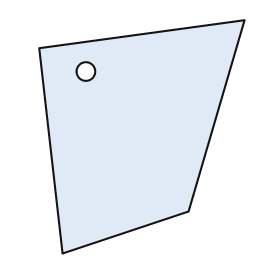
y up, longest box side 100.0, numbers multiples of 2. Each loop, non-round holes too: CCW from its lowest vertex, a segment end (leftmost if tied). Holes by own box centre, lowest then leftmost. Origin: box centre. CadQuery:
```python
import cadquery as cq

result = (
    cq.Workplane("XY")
    .moveTo(-34.0, -50.0)
    .lineTo(20.0, -32.0)
    .lineTo(44.0, 50.0)
    .lineTo(-44.0, 38.0)
    .close()
    .moveTo(-24.0, 28.0)
    .circle(4.0)
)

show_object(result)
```